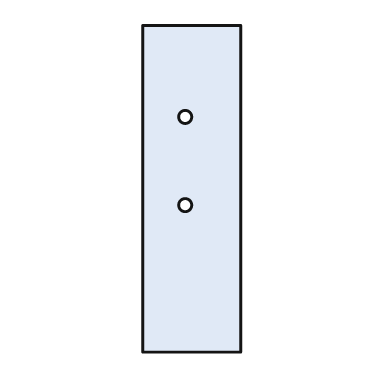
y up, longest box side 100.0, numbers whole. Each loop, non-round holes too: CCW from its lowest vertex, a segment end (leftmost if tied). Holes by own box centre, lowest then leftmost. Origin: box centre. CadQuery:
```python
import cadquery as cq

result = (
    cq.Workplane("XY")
    .moveTo(-15.0, -50.0)
    .lineTo(15.0, -50.0)
    .lineTo(15.0, 50.0)
    .lineTo(-15.0, 50.0)
    .close()
    .moveTo(-2.0, -5.0)
    .circle(2.0)
    .moveTo(-2.0, 22.0)
    .circle(2.0)
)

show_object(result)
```